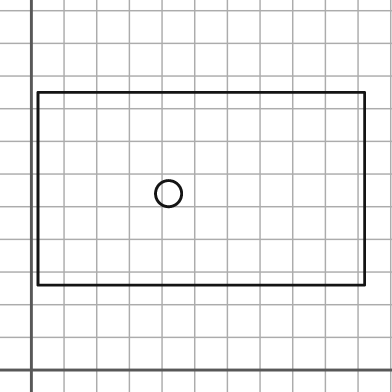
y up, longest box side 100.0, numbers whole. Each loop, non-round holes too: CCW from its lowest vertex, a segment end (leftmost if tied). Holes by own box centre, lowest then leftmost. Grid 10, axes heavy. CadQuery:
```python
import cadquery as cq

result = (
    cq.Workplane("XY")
    .moveTo(2.0, 26.0)
    .lineTo(102.0, 26.0)
    .lineTo(102.0, 85.0)
    .lineTo(2.0, 85.0)
    .close()
    .moveTo(42.0, 54.0)
    .circle(4.0)
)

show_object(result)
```